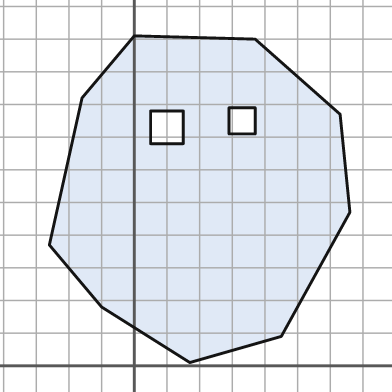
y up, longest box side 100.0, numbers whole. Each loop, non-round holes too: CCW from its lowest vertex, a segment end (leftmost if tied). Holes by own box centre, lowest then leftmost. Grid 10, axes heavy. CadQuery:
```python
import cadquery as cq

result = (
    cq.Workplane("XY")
    .moveTo(17.0, 1.0)
    .lineTo(45.0, 9.0)
    .lineTo(66.0, 47.0)
    .lineTo(63.0, 77.0)
    .lineTo(37.0, 100.0)
    .lineTo(0.0, 101.0)
    .lineTo(-16.0, 82.0)
    .lineTo(-26.0, 37.0)
    .lineTo(-10.0, 18.0)
    .close()
    .moveTo(5.0, 68.0)
    .lineTo(15.0, 68.0)
    .lineTo(15.0, 78.0)
    .lineTo(5.0, 78.0)
    .close()
    .moveTo(29.0, 71.0)
    .lineTo(37.0, 71.0)
    .lineTo(37.0, 79.0)
    .lineTo(29.0, 79.0)
    .close()
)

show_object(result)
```